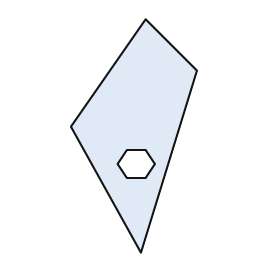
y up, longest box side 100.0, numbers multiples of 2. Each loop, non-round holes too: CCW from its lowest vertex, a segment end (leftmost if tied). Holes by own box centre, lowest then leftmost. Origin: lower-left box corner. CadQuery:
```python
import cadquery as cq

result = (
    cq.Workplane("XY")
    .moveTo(30.0, 0.0)
    .lineTo(54.0, 78.0)
    .lineTo(32.0, 100.0)
    .lineTo(0.0, 54.0)
    .close()
    .moveTo(24.0, 32.0)
    .lineTo(32.0, 32.0)
    .lineTo(36.0, 38.0)
    .lineTo(32.0, 44.0)
    .lineTo(24.0, 44.0)
    .lineTo(20.0, 38.0)
    .close()
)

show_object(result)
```